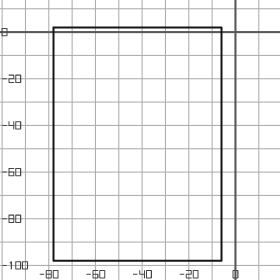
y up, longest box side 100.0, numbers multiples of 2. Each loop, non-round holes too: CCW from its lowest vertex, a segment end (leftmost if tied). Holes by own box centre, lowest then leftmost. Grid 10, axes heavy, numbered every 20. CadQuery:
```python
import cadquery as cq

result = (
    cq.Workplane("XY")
    .moveTo(-78.0, -98.0)
    .lineTo(-6.0, -98.0)
    .lineTo(-6.0, 2.0)
    .lineTo(-78.0, 2.0)
    .close()
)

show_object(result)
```